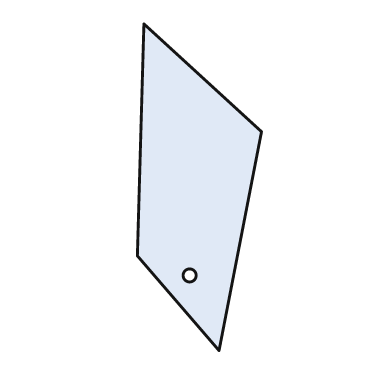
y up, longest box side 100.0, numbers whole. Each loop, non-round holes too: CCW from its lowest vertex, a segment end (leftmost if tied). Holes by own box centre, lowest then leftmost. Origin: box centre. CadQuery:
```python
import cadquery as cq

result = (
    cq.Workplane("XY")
    .moveTo(6.0, -50.0)
    .lineTo(19.0, 17.0)
    .lineTo(-17.0, 50.0)
    .lineTo(-19.0, -21.0)
    .close()
    .moveTo(-3.0, -27.0)
    .circle(2.0)
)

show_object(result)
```